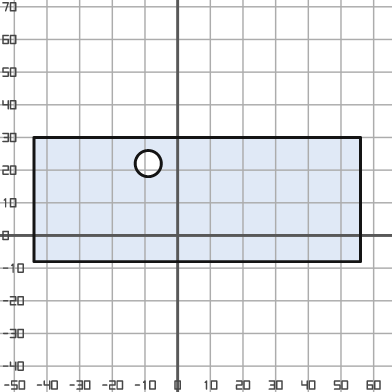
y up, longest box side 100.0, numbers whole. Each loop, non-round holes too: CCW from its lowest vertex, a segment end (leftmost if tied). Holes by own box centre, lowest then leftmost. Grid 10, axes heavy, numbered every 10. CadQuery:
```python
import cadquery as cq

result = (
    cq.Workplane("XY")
    .moveTo(-44.0, -8.0)
    .lineTo(56.0, -8.0)
    .lineTo(56.0, 30.0)
    .lineTo(-44.0, 30.0)
    .close()
    .moveTo(-9.0, 22.0)
    .circle(4.0)
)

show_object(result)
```